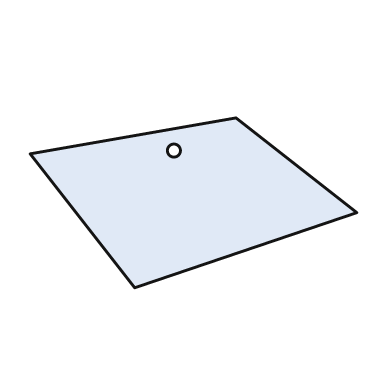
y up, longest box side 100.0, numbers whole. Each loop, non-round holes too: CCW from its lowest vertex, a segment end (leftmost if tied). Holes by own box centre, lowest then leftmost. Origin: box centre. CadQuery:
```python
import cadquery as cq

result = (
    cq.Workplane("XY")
    .moveTo(-18.0, -26.0)
    .lineTo(50.0, -3.0)
    .lineTo(13.0, 26.0)
    .lineTo(-50.0, 15.0)
    .close()
    .moveTo(-6.0, 16.0)
    .circle(2.0)
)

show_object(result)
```